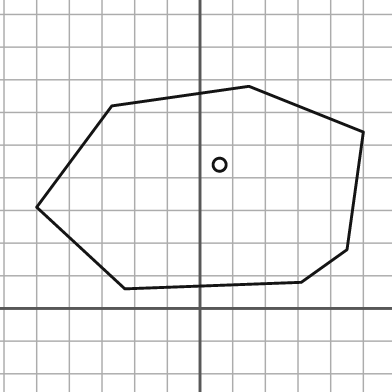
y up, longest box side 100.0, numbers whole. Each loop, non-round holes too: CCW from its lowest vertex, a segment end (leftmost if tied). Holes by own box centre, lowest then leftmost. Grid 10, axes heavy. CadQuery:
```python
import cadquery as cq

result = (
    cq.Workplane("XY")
    .moveTo(-23.0, 6.0)
    .lineTo(31.0, 8.0)
    .lineTo(45.0, 18.0)
    .lineTo(50.0, 54.0)
    .lineTo(15.0, 68.0)
    .lineTo(-27.0, 62.0)
    .lineTo(-50.0, 31.0)
    .close()
    .moveTo(6.0, 44.0)
    .circle(2.0)
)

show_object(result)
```